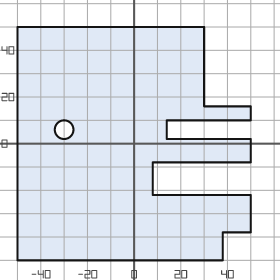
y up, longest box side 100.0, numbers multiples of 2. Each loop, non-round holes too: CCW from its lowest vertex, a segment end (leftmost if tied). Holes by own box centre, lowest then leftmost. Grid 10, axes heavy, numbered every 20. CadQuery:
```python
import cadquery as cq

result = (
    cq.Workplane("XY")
    .moveTo(-50.0, -50.0)
    .lineTo(38.0, -50.0)
    .lineTo(38.0, -38.0)
    .lineTo(50.0, -38.0)
    .lineTo(50.0, -22.0)
    .lineTo(8.0, -22.0)
    .lineTo(8.0, -8.0)
    .lineTo(50.0, -8.0)
    .lineTo(50.0, 2.0)
    .lineTo(14.0, 2.0)
    .lineTo(14.0, 10.0)
    .lineTo(50.0, 10.0)
    .lineTo(50.0, 16.0)
    .lineTo(30.0, 16.0)
    .lineTo(30.0, 50.0)
    .lineTo(-50.0, 50.0)
    .close()
    .moveTo(-30.0, 6.0)
    .circle(4.0)
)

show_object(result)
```